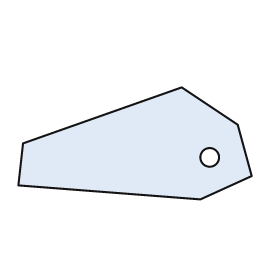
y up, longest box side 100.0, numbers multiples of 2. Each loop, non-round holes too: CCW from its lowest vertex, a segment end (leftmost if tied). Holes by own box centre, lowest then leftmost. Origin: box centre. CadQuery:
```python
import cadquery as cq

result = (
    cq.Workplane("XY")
    .moveTo(28.0, -24.0)
    .lineTo(50.0, -14.0)
    .lineTo(44.0, 8.0)
    .lineTo(20.0, 24.0)
    .lineTo(-48.0, 0.0)
    .lineTo(-50.0, -18.0)
    .close()
    .moveTo(32.0, -6.0)
    .circle(4.0)
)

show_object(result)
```